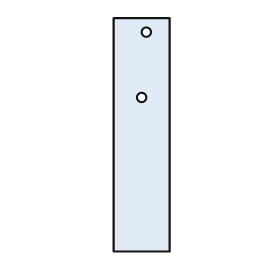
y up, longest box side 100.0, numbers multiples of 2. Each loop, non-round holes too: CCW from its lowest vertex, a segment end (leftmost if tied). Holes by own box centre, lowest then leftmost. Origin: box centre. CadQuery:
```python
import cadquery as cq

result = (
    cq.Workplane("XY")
    .moveTo(-12.0, -50.0)
    .lineTo(12.0, -50.0)
    .lineTo(12.0, 50.0)
    .lineTo(-12.0, 50.0)
    .close()
    .moveTo(0.0, 16.0)
    .circle(2.0)
    .moveTo(2.0, 44.0)
    .circle(2.0)
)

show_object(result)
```